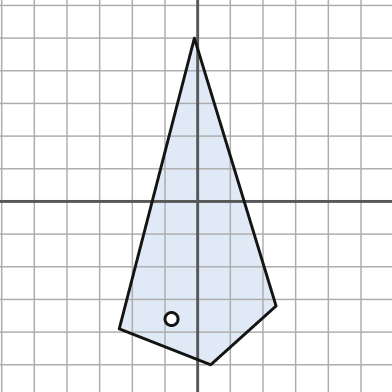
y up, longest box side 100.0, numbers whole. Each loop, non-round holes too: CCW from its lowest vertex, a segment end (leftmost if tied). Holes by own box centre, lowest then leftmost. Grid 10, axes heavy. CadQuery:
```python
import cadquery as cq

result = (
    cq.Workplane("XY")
    .moveTo(4.0, -50.0)
    .lineTo(24.0, -32.0)
    .lineTo(-1.0, 50.0)
    .lineTo(-24.0, -39.0)
    .close()
    .moveTo(-8.0, -36.0)
    .circle(2.0)
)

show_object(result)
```